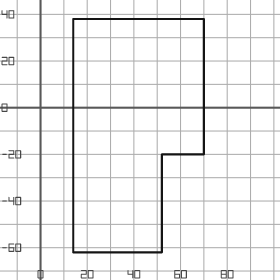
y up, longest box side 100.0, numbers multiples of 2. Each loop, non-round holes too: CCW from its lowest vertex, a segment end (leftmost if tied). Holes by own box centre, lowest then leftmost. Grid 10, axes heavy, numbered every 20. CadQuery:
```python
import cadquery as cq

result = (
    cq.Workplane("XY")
    .moveTo(14.0, -62.0)
    .lineTo(52.0, -62.0)
    .lineTo(52.0, -20.0)
    .lineTo(70.0, -20.0)
    .lineTo(70.0, 38.0)
    .lineTo(14.0, 38.0)
    .close()
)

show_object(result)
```